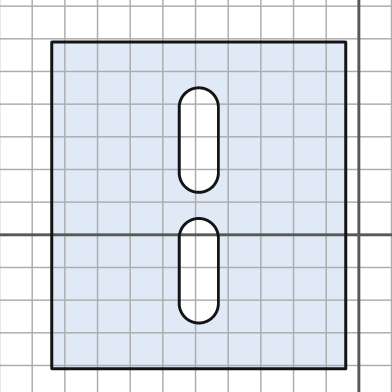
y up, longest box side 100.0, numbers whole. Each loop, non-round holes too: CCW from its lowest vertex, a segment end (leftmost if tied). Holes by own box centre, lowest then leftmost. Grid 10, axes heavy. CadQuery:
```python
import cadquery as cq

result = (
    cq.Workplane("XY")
    .moveTo(-94.0, -41.0)
    .lineTo(-4.0, -41.0)
    .lineTo(-4.0, 59.0)
    .lineTo(-94.0, 59.0)
    .close()
    .moveTo(-55.0, -21.0)
    .threePointArc((-49.0, -27.0), (-43.0, -21.0))
    .lineTo(-43.0, -1.0)
    .threePointArc((-49.0, 5.0), (-55.0, -1.0))
    .close()
    .moveTo(-55.0, 19.0)
    .threePointArc((-49.0, 13.0), (-43.0, 19.0))
    .lineTo(-43.0, 39.0)
    .threePointArc((-49.0, 45.0), (-55.0, 39.0))
    .close()
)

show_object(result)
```